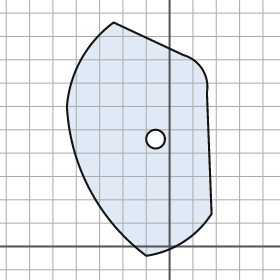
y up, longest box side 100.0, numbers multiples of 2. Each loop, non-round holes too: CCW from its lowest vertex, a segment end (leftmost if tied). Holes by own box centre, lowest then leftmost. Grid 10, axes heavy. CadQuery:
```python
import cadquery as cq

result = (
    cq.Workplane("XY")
    .moveTo(-10.0, -4.0)
    .threePointArc((6.0, 2.0), (18.0, 14.0))
    .lineTo(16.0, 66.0)
    .threePointArc((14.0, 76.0), (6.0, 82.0))
    .lineTo(-24.0, 96.0)
    .threePointArc((-38.0, 80.0), (-44.0, 60.0))
    .threePointArc((-34.0, 24.0), (-10.0, -4.0))
    .close()
    .moveTo(-6.0, 46.0)
    .circle(4.0)
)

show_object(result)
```